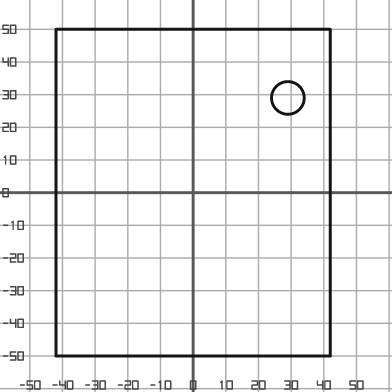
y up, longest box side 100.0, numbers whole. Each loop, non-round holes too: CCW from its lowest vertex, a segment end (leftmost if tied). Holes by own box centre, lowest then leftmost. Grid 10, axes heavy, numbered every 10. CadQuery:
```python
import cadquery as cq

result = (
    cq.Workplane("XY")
    .moveTo(-42.0, -50.0)
    .lineTo(42.0, -50.0)
    .lineTo(42.0, 50.0)
    .lineTo(-42.0, 50.0)
    .close()
    .moveTo(29.0, 29.0)
    .circle(5.0)
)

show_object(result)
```